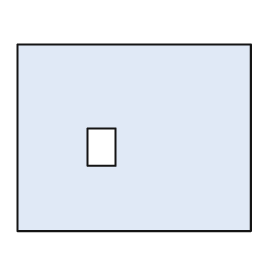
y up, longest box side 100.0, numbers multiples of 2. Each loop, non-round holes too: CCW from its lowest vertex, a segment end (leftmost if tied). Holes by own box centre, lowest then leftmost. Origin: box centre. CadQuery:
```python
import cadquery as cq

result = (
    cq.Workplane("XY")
    .moveTo(-50.0, -40.0)
    .lineTo(50.0, -40.0)
    .lineTo(50.0, 40.0)
    .lineTo(-50.0, 40.0)
    .close()
    .moveTo(-20.0, -12.0)
    .lineTo(-8.0, -12.0)
    .lineTo(-8.0, 4.0)
    .lineTo(-20.0, 4.0)
    .close()
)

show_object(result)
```